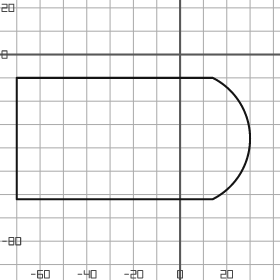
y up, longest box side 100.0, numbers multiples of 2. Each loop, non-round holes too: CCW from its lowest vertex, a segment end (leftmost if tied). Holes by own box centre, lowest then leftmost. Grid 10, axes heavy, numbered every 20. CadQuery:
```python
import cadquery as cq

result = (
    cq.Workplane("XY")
    .moveTo(-70.0, -62.0)
    .lineTo(14.0, -62.0)
    .threePointArc((30.0, -36.0), (14.0, -10.0))
    .lineTo(-70.0, -10.0)
    .close()
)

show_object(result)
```